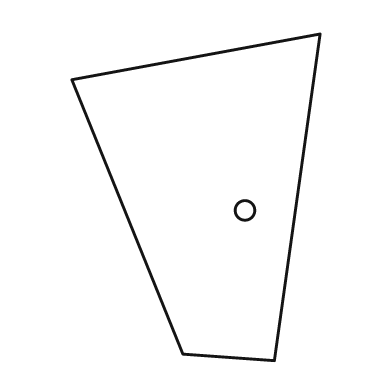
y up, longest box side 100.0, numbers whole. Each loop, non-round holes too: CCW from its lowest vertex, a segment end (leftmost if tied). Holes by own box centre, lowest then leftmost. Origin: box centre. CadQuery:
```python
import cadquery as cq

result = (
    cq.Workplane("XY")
    .moveTo(24.0, -50.0)
    .lineTo(38.0, 50.0)
    .lineTo(-38.0, 36.0)
    .lineTo(-4.0, -48.0)
    .close()
    .moveTo(15.0, -4.0)
    .circle(3.0)
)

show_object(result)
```